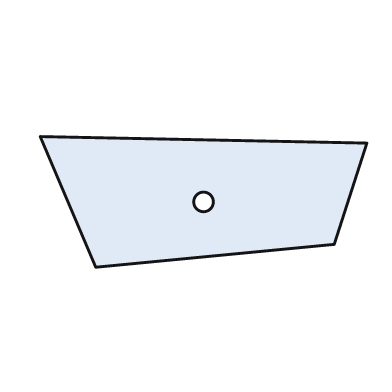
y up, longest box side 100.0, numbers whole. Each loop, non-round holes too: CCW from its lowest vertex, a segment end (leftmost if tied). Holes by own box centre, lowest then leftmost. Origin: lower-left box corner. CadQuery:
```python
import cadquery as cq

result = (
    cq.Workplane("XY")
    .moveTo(17.0, 0.0)
    .lineTo(90.0, 7.0)
    .lineTo(100.0, 38.0)
    .lineTo(0.0, 40.0)
    .close()
    .moveTo(50.0, 20.0)
    .circle(3.0)
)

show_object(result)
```